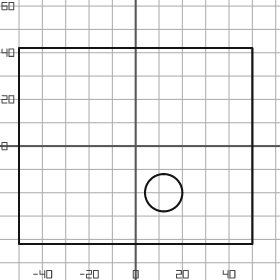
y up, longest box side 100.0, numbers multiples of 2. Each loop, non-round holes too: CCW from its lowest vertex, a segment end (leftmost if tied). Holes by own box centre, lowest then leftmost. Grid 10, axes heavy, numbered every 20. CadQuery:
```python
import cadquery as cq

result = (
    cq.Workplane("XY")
    .moveTo(-50.0, -42.0)
    .lineTo(50.0, -42.0)
    .lineTo(50.0, 42.0)
    .lineTo(-50.0, 42.0)
    .close()
    .moveTo(12.0, -20.0)
    .circle(8.0)
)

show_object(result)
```